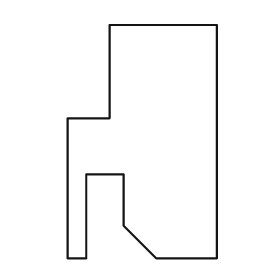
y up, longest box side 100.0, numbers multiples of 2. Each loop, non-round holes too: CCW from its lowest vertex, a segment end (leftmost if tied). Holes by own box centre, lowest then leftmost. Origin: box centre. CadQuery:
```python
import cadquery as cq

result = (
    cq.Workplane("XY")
    .moveTo(-32.0, -50.0)
    .lineTo(-24.0, -50.0)
    .lineTo(-24.0, -14.0)
    .lineTo(-8.0, -14.0)
    .lineTo(-8.0, -36.0)
    .lineTo(6.0, -50.0)
    .lineTo(32.0, -50.0)
    .lineTo(32.0, 50.0)
    .lineTo(-14.0, 50.0)
    .lineTo(-14.0, 10.0)
    .lineTo(-32.0, 10.0)
    .close()
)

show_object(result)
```